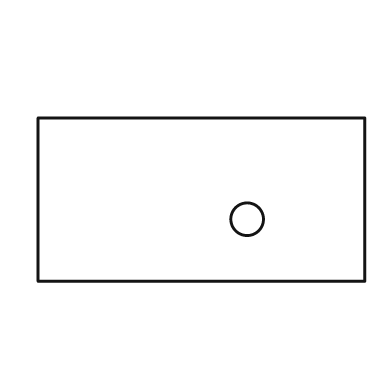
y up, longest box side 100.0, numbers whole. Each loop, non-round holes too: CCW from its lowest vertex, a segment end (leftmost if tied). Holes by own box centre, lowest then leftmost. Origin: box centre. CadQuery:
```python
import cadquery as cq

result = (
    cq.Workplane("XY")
    .moveTo(-50.0, -25.0)
    .lineTo(50.0, -25.0)
    .lineTo(50.0, 25.0)
    .lineTo(-50.0, 25.0)
    .close()
    .moveTo(14.0, -6.0)
    .circle(5.0)
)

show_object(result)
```